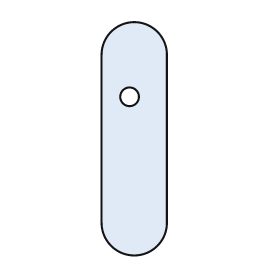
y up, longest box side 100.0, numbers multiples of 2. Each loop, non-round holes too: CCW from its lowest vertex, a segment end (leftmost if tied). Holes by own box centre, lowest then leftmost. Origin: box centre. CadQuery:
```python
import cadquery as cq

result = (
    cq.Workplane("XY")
    .moveTo(-14.0, -36.0)
    .threePointArc((0.0, -50.0), (14.0, -36.0))
    .lineTo(14.0, 36.0)
    .threePointArc((0.0, 50.0), (-14.0, 36.0))
    .close()
    .moveTo(-2.0, 18.0)
    .circle(4.0)
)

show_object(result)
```